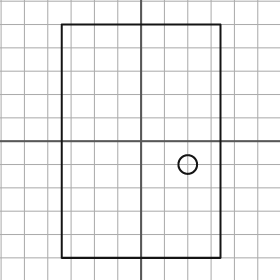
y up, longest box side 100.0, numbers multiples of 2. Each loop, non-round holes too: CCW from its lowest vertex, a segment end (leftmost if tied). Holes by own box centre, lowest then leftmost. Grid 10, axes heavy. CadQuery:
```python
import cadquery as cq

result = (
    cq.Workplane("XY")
    .moveTo(-34.0, -50.0)
    .lineTo(34.0, -50.0)
    .lineTo(34.0, 50.0)
    .lineTo(-34.0, 50.0)
    .close()
    .moveTo(20.0, -10.0)
    .circle(4.0)
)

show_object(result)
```